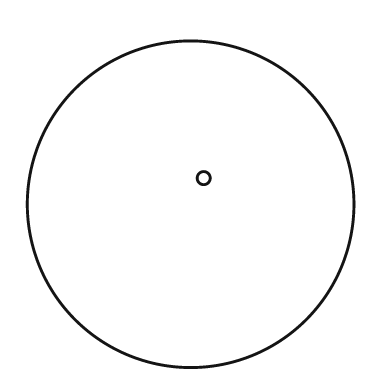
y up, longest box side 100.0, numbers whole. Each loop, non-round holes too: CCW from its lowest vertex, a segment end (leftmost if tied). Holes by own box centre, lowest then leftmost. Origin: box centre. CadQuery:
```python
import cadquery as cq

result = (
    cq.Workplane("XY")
    .moveTo(0.0, 0.0)
    .circle(50.0)
    .moveTo(4.0, 8.0)
    .circle(2.0)
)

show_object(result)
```